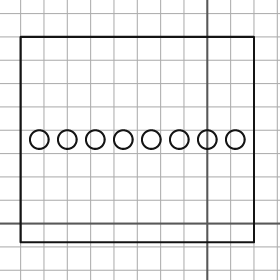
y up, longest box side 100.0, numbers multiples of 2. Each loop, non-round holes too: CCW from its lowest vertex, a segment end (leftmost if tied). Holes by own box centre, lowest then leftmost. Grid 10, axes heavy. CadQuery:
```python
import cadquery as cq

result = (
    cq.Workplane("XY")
    .moveTo(-80.0, -8.0)
    .lineTo(20.0, -8.0)
    .lineTo(20.0, 80.0)
    .lineTo(-80.0, 80.0)
    .close()
    .moveTo(-72.0, 36.0)
    .circle(4.0)
    .moveTo(-60.0, 36.0)
    .circle(4.0)
    .moveTo(-48.0, 36.0)
    .circle(4.0)
    .moveTo(-36.0, 36.0)
    .circle(4.0)
    .moveTo(-24.0, 36.0)
    .circle(4.0)
    .moveTo(-12.0, 36.0)
    .circle(4.0)
    .moveTo(0.0, 36.0)
    .circle(4.0)
    .moveTo(12.0, 36.0)
    .circle(4.0)
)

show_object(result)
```